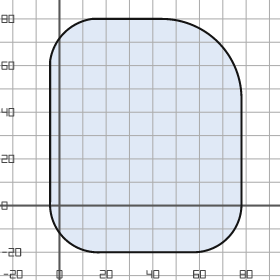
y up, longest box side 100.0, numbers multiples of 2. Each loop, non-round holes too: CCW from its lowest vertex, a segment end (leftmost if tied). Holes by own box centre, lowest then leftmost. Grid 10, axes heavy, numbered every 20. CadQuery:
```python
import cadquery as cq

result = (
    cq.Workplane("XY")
    .moveTo(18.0, -20.0)
    .lineTo(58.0, -20.0)
    .threePointArc((72.0, -14.0), (78.0, 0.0))
    .lineTo(78.0, 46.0)
    .threePointArc((68.0, 70.0), (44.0, 80.0))
    .lineTo(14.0, 80.0)
    .threePointArc((2.0, 74.0), (-4.0, 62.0))
    .lineTo(-4.0, 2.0)
    .threePointArc((2.0, -14.0), (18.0, -20.0))
    .close()
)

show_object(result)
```